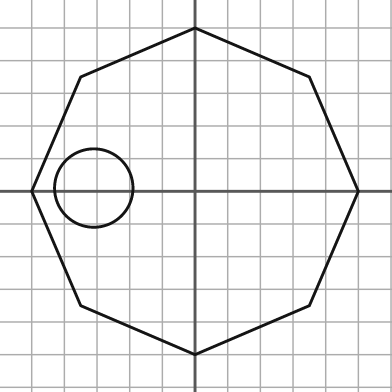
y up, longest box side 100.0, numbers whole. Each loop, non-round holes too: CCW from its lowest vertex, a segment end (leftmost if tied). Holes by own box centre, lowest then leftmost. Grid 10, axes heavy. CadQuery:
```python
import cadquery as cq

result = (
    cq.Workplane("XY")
    .moveTo(0.0, -50.0)
    .lineTo(35.0, -35.0)
    .lineTo(50.0, 0.0)
    .lineTo(35.0, 35.0)
    .lineTo(0.0, 50.0)
    .lineTo(-35.0, 35.0)
    .lineTo(-50.0, 0.0)
    .lineTo(-35.0, -35.0)
    .close()
    .moveTo(-31.0, 1.0)
    .circle(12.0)
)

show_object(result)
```